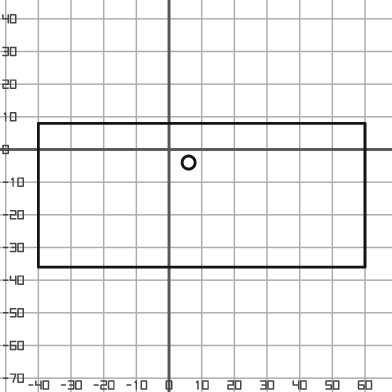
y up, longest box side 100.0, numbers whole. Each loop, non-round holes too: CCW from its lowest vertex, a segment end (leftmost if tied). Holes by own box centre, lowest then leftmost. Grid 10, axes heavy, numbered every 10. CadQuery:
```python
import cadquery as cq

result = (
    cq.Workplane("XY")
    .moveTo(-40.0, -36.0)
    .lineTo(60.0, -36.0)
    .lineTo(60.0, 8.0)
    .lineTo(-40.0, 8.0)
    .close()
    .moveTo(6.0, -4.0)
    .circle(2.0)
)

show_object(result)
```